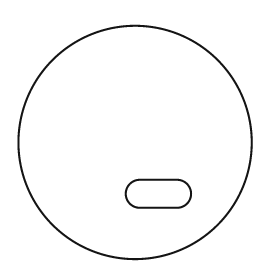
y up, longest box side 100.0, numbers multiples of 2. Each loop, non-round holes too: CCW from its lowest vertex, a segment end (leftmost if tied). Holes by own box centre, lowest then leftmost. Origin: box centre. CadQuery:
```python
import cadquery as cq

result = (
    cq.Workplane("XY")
    .moveTo(0.0, 0.0)
    .circle(50.0)
    .moveTo(2.0, -28.0)
    .lineTo(18.0, -28.0)
    .threePointArc((24.0, -22.0), (18.0, -16.0))
    .lineTo(2.0, -16.0)
    .threePointArc((-4.0, -22.0), (2.0, -28.0))
    .close()
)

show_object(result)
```